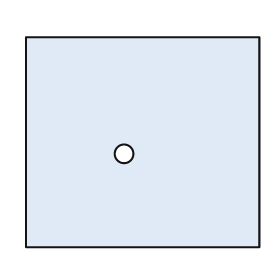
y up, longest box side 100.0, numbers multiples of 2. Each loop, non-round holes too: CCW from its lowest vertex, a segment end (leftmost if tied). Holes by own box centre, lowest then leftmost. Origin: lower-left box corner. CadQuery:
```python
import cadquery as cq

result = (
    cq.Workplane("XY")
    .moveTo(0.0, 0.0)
    .lineTo(100.0, 0.0)
    .lineTo(100.0, 90.0)
    .lineTo(0.0, 90.0)
    .close()
    .moveTo(42.0, 40.0)
    .circle(4.0)
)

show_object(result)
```